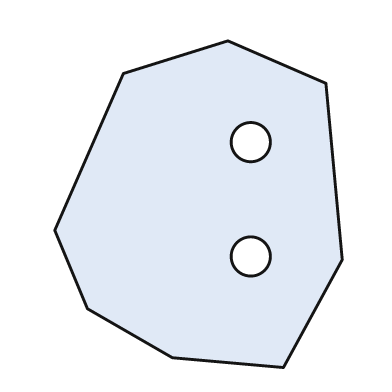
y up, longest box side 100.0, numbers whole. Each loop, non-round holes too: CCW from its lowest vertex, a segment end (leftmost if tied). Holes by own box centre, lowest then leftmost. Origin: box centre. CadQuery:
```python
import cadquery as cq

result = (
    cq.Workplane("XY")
    .moveTo(26.0, -50.0)
    .lineTo(44.0, -17.0)
    .lineTo(39.0, 37.0)
    .lineTo(9.0, 50.0)
    .lineTo(-23.0, 40.0)
    .lineTo(-44.0, -8.0)
    .lineTo(-34.0, -32.0)
    .lineTo(-8.0, -47.0)
    .close()
    .moveTo(16.0, -16.0)
    .circle(6.0)
    .moveTo(16.0, 19.0)
    .circle(6.0)
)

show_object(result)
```